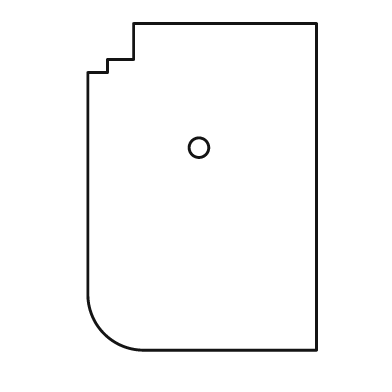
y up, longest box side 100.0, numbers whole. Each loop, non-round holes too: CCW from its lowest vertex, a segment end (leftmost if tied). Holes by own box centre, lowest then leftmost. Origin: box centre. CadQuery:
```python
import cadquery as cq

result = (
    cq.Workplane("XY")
    .moveTo(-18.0, -50.0)
    .lineTo(35.0, -50.0)
    .lineTo(35.0, 50.0)
    .lineTo(-21.0, 50.0)
    .lineTo(-21.0, 39.0)
    .lineTo(-29.0, 39.0)
    .lineTo(-29.0, 35.0)
    .lineTo(-35.0, 35.0)
    .lineTo(-35.0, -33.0)
    .threePointArc((-30.0, -45.0), (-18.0, -50.0))
    .close()
    .moveTo(-1.0, 12.0)
    .circle(3.0)
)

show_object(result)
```